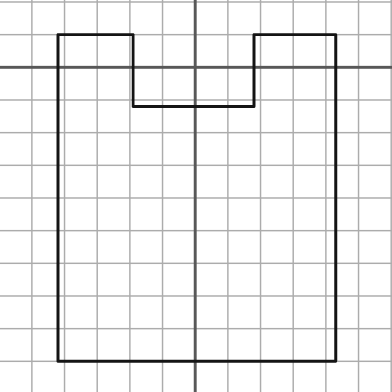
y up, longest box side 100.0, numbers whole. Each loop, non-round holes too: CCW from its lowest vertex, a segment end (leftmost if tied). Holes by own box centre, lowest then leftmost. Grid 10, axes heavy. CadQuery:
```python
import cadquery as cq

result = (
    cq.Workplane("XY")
    .moveTo(-42.0, -90.0)
    .lineTo(43.0, -90.0)
    .lineTo(43.0, 10.0)
    .lineTo(18.0, 10.0)
    .lineTo(18.0, -12.0)
    .lineTo(-19.0, -12.0)
    .lineTo(-19.0, 10.0)
    .lineTo(-42.0, 10.0)
    .close()
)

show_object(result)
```